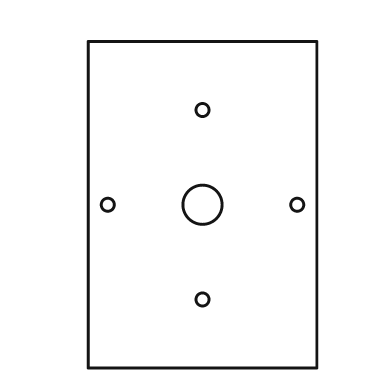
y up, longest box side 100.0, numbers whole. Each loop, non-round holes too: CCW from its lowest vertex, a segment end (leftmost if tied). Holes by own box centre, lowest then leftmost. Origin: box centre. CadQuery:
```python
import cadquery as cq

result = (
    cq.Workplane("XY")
    .moveTo(-35.0, -50.0)
    .lineTo(35.0, -50.0)
    .lineTo(35.0, 50.0)
    .lineTo(-35.0, 50.0)
    .close()
    .moveTo(0.0, -29.0)
    .circle(2.0)
    .moveTo(-29.0, 0.0)
    .circle(2.0)
    .moveTo(0.0, 0.0)
    .circle(6.0)
    .moveTo(29.0, 0.0)
    .circle(2.0)
    .moveTo(0.0, 29.0)
    .circle(2.0)
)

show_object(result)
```